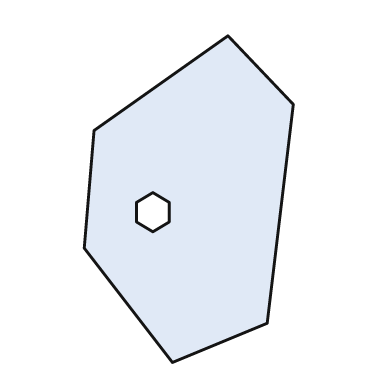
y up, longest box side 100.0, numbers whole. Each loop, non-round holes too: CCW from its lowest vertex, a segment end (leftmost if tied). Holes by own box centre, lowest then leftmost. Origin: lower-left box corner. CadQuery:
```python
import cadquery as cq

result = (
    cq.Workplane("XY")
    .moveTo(27.0, 0.0)
    .lineTo(56.0, 12.0)
    .lineTo(64.0, 79.0)
    .lineTo(44.0, 100.0)
    .lineTo(3.0, 71.0)
    .lineTo(0.0, 35.0)
    .close()
    .moveTo(21.0, 40.0)
    .lineTo(26.0, 43.0)
    .lineTo(26.0, 49.0)
    .lineTo(21.0, 52.0)
    .lineTo(16.0, 49.0)
    .lineTo(16.0, 43.0)
    .close()
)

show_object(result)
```